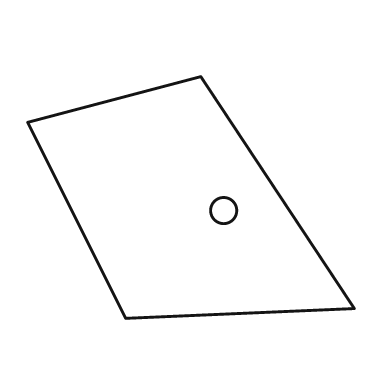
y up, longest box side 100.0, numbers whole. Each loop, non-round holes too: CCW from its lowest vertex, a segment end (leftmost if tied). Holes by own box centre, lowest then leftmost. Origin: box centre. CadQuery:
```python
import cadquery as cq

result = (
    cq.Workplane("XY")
    .moveTo(-20.0, -37.0)
    .lineTo(50.0, -34.0)
    .lineTo(3.0, 37.0)
    .lineTo(-50.0, 23.0)
    .close()
    .moveTo(10.0, -4.0)
    .circle(4.0)
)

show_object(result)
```